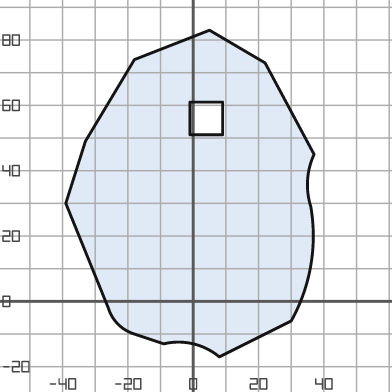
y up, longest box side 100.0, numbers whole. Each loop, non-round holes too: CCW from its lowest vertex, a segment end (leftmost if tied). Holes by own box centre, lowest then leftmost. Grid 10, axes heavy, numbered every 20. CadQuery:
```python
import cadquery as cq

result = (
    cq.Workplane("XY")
    .moveTo(8.0, -17.0)
    .lineTo(30.0, -6.0)
    .threePointArc((36.0, 11.0), (36.0, 29.0))
    .threePointArc((35.0, 37.0), (37.0, 45.0))
    .lineTo(22.0, 73.0)
    .lineTo(5.0, 83.0)
    .lineTo(-18.0, 74.0)
    .lineTo(-33.0, 49.0)
    .lineTo(-39.0, 30.0)
    .lineTo(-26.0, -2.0)
    .threePointArc((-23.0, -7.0), (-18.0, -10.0))
    .lineTo(-9.0, -13.0)
    .threePointArc((0.0, -13.0), (8.0, -17.0))
    .close()
    .moveTo(-1.0, 51.0)
    .lineTo(9.0, 51.0)
    .lineTo(9.0, 61.0)
    .lineTo(-1.0, 61.0)
    .close()
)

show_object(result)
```